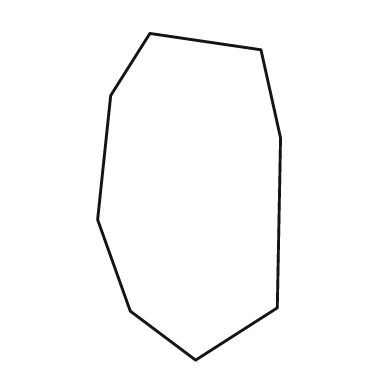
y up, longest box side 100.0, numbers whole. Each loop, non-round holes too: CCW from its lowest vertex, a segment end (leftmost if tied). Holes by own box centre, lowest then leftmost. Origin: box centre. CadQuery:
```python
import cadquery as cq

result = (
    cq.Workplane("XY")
    .moveTo(2.0, -50.0)
    .lineTo(27.0, -34.0)
    .lineTo(28.0, 18.0)
    .lineTo(22.0, 45.0)
    .lineTo(-12.0, 50.0)
    .lineTo(-24.0, 31.0)
    .lineTo(-28.0, -7.0)
    .lineTo(-18.0, -35.0)
    .close()
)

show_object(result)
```